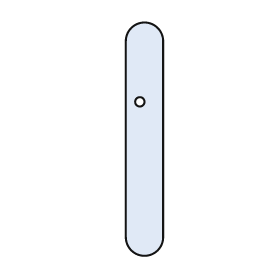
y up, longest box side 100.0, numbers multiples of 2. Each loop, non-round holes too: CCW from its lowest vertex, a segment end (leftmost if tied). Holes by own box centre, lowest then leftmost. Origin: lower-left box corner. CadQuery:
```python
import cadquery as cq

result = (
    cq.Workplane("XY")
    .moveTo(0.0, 8.0)
    .threePointArc((8.0, 0.0), (16.0, 8.0))
    .lineTo(16.0, 92.0)
    .threePointArc((8.0, 100.0), (0.0, 92.0))
    .close()
    .moveTo(6.0, 66.0)
    .circle(2.0)
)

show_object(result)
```